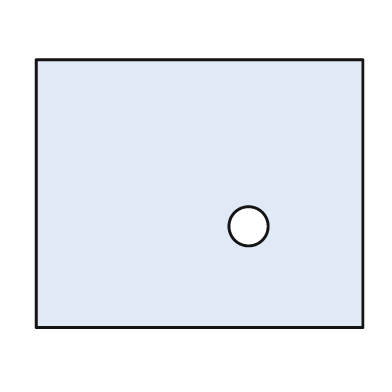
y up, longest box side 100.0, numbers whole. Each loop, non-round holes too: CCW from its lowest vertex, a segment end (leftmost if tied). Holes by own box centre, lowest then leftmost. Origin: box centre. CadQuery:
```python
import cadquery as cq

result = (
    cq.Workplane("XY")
    .moveTo(-50.0, -41.0)
    .lineTo(50.0, -41.0)
    .lineTo(50.0, 41.0)
    .lineTo(-50.0, 41.0)
    .close()
    .moveTo(15.0, -10.0)
    .circle(6.0)
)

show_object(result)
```